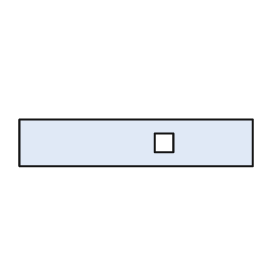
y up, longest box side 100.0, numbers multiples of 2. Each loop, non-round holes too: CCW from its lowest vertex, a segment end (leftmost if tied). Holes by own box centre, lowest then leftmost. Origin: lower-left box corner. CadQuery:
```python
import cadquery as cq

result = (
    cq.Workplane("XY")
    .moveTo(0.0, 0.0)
    .lineTo(100.0, 0.0)
    .lineTo(100.0, 20.0)
    .lineTo(0.0, 20.0)
    .close()
    .moveTo(58.0, 6.0)
    .lineTo(66.0, 6.0)
    .lineTo(66.0, 14.0)
    .lineTo(58.0, 14.0)
    .close()
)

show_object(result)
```